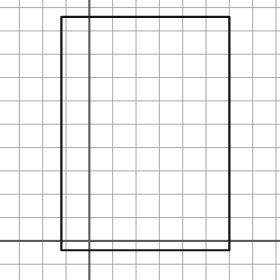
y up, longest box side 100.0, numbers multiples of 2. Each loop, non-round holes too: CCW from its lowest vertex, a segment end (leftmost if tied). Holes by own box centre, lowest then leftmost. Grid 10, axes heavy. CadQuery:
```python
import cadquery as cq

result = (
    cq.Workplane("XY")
    .moveTo(-12.0, -4.0)
    .lineTo(60.0, -4.0)
    .lineTo(60.0, 96.0)
    .lineTo(-12.0, 96.0)
    .close()
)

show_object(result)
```